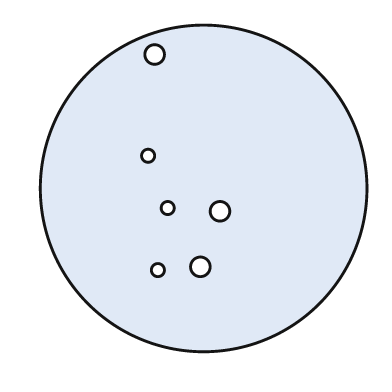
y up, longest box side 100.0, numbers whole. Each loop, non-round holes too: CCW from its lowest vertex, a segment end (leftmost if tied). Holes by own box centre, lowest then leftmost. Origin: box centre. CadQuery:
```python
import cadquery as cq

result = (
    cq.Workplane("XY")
    .moveTo(0.0, 0.0)
    .circle(50.0)
    .moveTo(-14.0, -25.0)
    .circle(2.0)
    .moveTo(-1.0, -24.0)
    .circle(3.0)
    .moveTo(5.0, -7.0)
    .circle(3.0)
    .moveTo(-11.0, -6.0)
    .circle(2.0)
    .moveTo(-17.0, 10.0)
    .circle(2.0)
    .moveTo(-15.0, 41.0)
    .circle(3.0)
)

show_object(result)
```